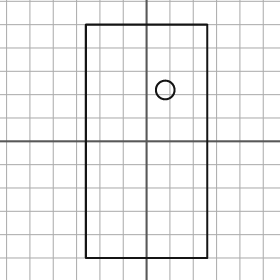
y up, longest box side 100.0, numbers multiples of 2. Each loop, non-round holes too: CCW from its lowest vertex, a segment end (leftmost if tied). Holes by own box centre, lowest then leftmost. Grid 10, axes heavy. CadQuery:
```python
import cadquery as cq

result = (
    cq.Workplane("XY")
    .moveTo(-26.0, -50.0)
    .lineTo(26.0, -50.0)
    .lineTo(26.0, 50.0)
    .lineTo(-26.0, 50.0)
    .close()
    .moveTo(8.0, 22.0)
    .circle(4.0)
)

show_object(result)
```